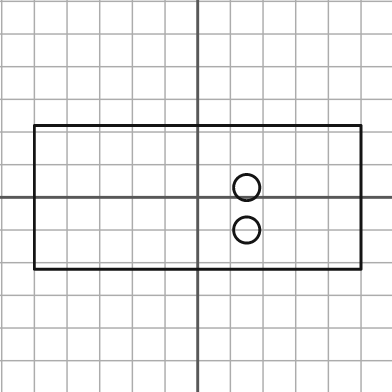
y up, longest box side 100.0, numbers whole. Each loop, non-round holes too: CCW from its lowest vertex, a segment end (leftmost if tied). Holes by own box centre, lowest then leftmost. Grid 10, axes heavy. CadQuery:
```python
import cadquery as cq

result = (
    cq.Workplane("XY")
    .moveTo(-50.0, -22.0)
    .lineTo(50.0, -22.0)
    .lineTo(50.0, 22.0)
    .lineTo(-50.0, 22.0)
    .close()
    .moveTo(15.0, -10.0)
    .circle(4.0)
    .moveTo(15.0, 3.0)
    .circle(4.0)
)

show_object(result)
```